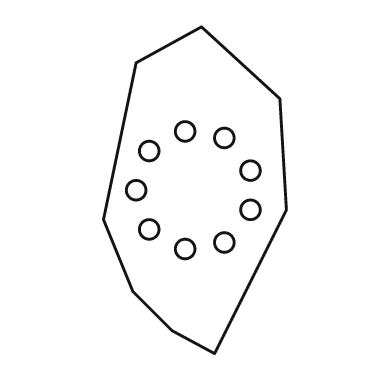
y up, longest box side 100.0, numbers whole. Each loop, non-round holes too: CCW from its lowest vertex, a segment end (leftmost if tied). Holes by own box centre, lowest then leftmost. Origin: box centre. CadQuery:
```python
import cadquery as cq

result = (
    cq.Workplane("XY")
    .moveTo(6.0, -50.0)
    .lineTo(28.0, -6.0)
    .lineTo(26.0, 28.0)
    .lineTo(2.0, 50.0)
    .lineTo(-18.0, 39.0)
    .lineTo(-28.0, -9.0)
    .lineTo(-19.0, -31.0)
    .lineTo(-7.0, -43.0)
    .close()
    .moveTo(-3.0, -18.0)
    .circle(3.0)
    .moveTo(9.0, -16.0)
    .circle(3.0)
    .moveTo(-14.0, -12.0)
    .circle(3.0)
    .moveTo(17.0, -6.0)
    .circle(3.0)
    .moveTo(-18.0, 0.0)
    .circle(3.0)
    .moveTo(17.0, 6.0)
    .circle(3.0)
    .moveTo(-14.0, 12.0)
    .circle(3.0)
    .moveTo(9.0, 16.0)
    .circle(3.0)
    .moveTo(-3.0, 18.0)
    .circle(3.0)
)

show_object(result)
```